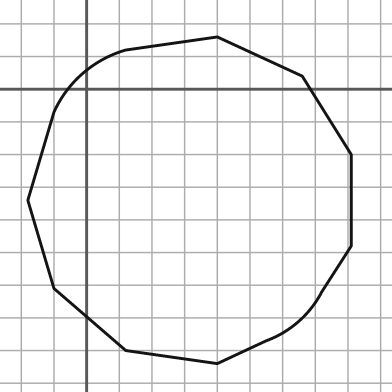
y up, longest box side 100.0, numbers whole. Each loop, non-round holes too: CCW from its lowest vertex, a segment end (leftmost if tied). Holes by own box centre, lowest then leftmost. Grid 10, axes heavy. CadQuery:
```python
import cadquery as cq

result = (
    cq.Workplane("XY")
    .moveTo(40.0, -84.0)
    .lineTo(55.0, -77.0)
    .threePointArc((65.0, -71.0), (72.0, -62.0))
    .lineTo(81.0, -48.0)
    .lineTo(81.0, -20.0)
    .lineTo(66.0, 4.0)
    .lineTo(40.0, 16.0)
    .lineTo(12.0, 12.0)
    .threePointArc((-1.0, 5.0), (-10.0, -7.0))
    .lineTo(-18.0, -34.0)
    .lineTo(-10.0, -61.0)
    .lineTo(12.0, -80.0)
    .close()
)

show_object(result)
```